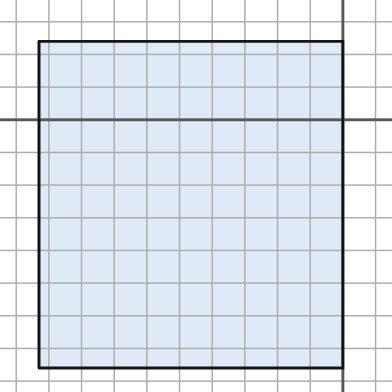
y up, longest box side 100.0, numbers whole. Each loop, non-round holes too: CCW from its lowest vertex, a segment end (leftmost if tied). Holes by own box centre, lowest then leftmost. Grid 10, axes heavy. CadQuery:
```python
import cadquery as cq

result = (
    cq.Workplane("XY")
    .moveTo(-93.0, -76.0)
    .lineTo(0.0, -76.0)
    .lineTo(0.0, 24.0)
    .lineTo(-93.0, 24.0)
    .close()
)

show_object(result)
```